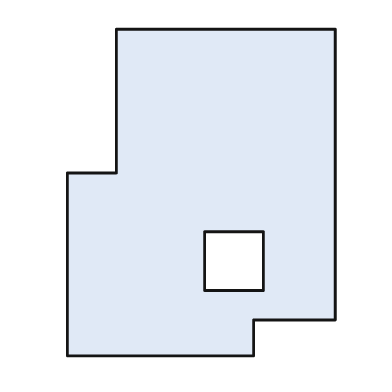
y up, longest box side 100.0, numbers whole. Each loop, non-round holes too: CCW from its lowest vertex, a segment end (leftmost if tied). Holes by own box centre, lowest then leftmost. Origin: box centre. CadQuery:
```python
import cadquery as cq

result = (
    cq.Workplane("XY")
    .moveTo(-41.0, -50.0)
    .lineTo(16.0, -50.0)
    .lineTo(16.0, -39.0)
    .lineTo(41.0, -39.0)
    .lineTo(41.0, 50.0)
    .lineTo(-26.0, 50.0)
    .lineTo(-26.0, 6.0)
    .lineTo(-41.0, 6.0)
    .close()
    .moveTo(1.0, -30.0)
    .lineTo(19.0, -30.0)
    .lineTo(19.0, -12.0)
    .lineTo(1.0, -12.0)
    .close()
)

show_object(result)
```